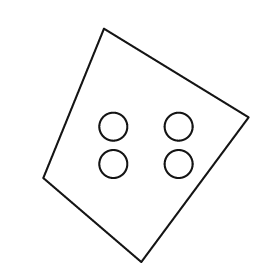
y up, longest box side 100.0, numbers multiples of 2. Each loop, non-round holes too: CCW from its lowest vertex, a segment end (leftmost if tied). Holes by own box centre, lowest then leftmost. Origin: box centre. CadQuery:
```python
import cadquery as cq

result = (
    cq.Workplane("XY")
    .moveTo(-2.0, -50.0)
    .lineTo(44.0, 12.0)
    .lineTo(-18.0, 50.0)
    .lineTo(-44.0, -14.0)
    .close()
    .moveTo(-14.0, -8.0)
    .circle(6.0)
    .moveTo(14.0, -8.0)
    .circle(6.0)
    .moveTo(-14.0, 8.0)
    .circle(6.0)
    .moveTo(14.0, 8.0)
    .circle(6.0)
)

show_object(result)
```